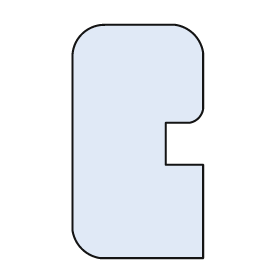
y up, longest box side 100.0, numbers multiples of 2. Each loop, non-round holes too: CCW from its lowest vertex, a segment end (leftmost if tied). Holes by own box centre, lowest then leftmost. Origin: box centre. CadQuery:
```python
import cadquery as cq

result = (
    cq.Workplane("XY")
    .moveTo(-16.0, -50.0)
    .lineTo(28.0, -50.0)
    .lineTo(28.0, -10.0)
    .lineTo(12.0, -10.0)
    .lineTo(12.0, 8.0)
    .lineTo(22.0, 8.0)
    .threePointArc((26.0, 10.0), (28.0, 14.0))
    .lineTo(28.0, 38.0)
    .threePointArc((24.0, 46.0), (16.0, 50.0))
    .lineTo(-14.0, 50.0)
    .threePointArc((-24.0, 46.0), (-28.0, 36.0))
    .lineTo(-28.0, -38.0)
    .threePointArc((-24.0, -46.0), (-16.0, -50.0))
    .close()
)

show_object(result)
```